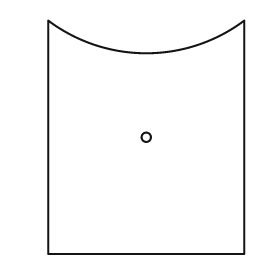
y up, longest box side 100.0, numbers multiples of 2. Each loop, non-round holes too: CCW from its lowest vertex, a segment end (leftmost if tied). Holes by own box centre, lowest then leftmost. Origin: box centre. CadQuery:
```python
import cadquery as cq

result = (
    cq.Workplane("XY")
    .moveTo(-42.0, -50.0)
    .lineTo(42.0, -50.0)
    .lineTo(42.0, 50.0)
    .threePointArc((0.0, 36.0), (-42.0, 50.0))
    .close()
    .moveTo(0.0, 0.0)
    .circle(2.0)
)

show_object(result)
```